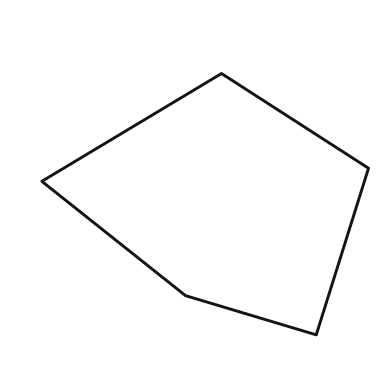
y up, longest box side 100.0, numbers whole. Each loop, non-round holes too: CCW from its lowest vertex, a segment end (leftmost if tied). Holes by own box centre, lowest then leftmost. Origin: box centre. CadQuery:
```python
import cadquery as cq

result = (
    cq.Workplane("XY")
    .moveTo(34.0, -40.0)
    .lineTo(50.0, 11.0)
    .lineTo(5.0, 40.0)
    .lineTo(-50.0, 7.0)
    .lineTo(-6.0, -28.0)
    .close()
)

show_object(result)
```